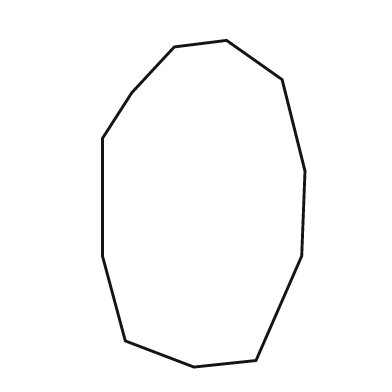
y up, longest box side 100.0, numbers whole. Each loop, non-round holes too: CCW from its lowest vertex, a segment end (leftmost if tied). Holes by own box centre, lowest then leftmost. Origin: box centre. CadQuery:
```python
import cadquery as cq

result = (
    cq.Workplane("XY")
    .moveTo(-3.0, -50.0)
    .lineTo(16.0, -48.0)
    .lineTo(30.0, -16.0)
    .lineTo(31.0, 10.0)
    .lineTo(24.0, 38.0)
    .lineTo(7.0, 50.0)
    .lineTo(-9.0, 48.0)
    .lineTo(-22.0, 34.0)
    .lineTo(-31.0, 20.0)
    .lineTo(-31.0, -16.0)
    .lineTo(-24.0, -42.0)
    .close()
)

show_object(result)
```